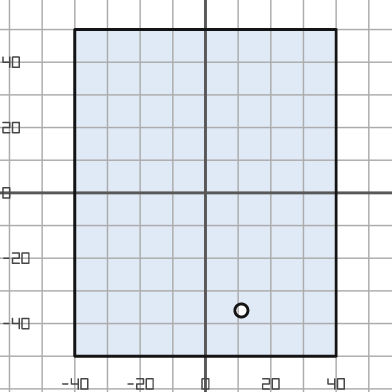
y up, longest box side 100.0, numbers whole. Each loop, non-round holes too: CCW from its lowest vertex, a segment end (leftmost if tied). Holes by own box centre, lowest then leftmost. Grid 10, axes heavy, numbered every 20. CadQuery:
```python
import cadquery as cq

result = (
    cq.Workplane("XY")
    .moveTo(-40.0, -50.0)
    .lineTo(40.0, -50.0)
    .lineTo(40.0, 50.0)
    .lineTo(-40.0, 50.0)
    .close()
    .moveTo(11.0, -36.0)
    .circle(2.0)
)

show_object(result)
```